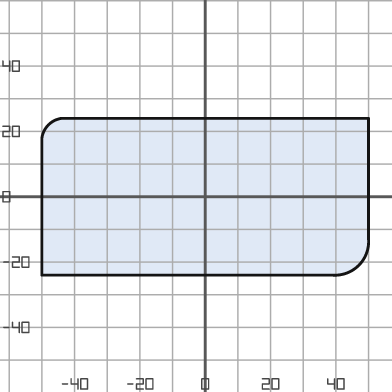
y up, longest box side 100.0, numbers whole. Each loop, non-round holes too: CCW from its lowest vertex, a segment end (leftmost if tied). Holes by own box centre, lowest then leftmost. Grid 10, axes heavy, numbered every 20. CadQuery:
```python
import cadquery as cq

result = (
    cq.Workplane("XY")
    .moveTo(-50.0, -24.0)
    .lineTo(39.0, -24.0)
    .threePointArc((47.0, -21.0), (50.0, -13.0))
    .lineTo(50.0, 24.0)
    .lineTo(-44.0, 24.0)
    .threePointArc((-48.0, 22.0), (-50.0, 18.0))
    .close()
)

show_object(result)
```